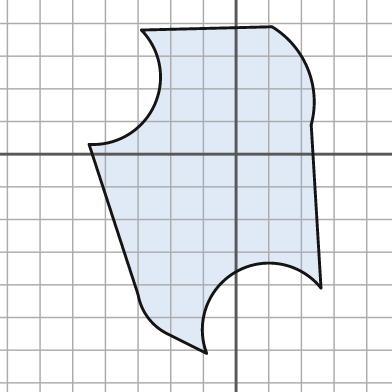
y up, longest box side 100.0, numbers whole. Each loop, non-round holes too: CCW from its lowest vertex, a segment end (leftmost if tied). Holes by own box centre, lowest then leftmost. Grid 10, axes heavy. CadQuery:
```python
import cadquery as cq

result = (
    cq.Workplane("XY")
    .moveTo(-9.0, -61.0)
    .threePointArc((0.0, -36.0), (26.0, -41.0))
    .lineTo(23.0, 9.0)
    .threePointArc((22.0, 26.0), (11.0, 39.0))
    .lineTo(-29.0, 38.0)
    .threePointArc((-25.0, 15.0), (-45.0, 3.0))
    .lineTo(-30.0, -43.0)
    .threePointArc((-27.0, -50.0), (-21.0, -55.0))
    .close()
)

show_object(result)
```